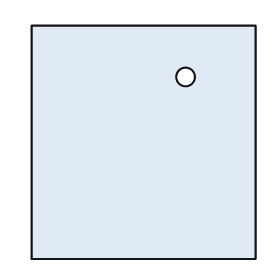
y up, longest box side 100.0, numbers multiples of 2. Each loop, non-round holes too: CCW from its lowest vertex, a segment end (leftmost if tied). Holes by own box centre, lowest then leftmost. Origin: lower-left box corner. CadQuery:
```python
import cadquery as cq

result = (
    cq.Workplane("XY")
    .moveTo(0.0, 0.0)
    .lineTo(96.0, 0.0)
    .lineTo(96.0, 100.0)
    .lineTo(0.0, 100.0)
    .close()
    .moveTo(66.0, 78.0)
    .circle(4.0)
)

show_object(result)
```